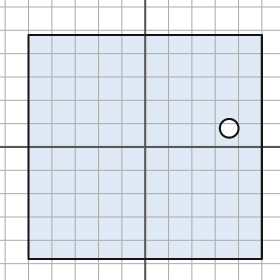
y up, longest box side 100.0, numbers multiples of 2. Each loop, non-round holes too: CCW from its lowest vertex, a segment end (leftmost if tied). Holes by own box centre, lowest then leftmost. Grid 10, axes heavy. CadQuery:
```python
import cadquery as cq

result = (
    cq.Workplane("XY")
    .moveTo(-50.0, -48.0)
    .lineTo(50.0, -48.0)
    .lineTo(50.0, 48.0)
    .lineTo(-50.0, 48.0)
    .close()
    .moveTo(36.0, 8.0)
    .circle(4.0)
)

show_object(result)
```